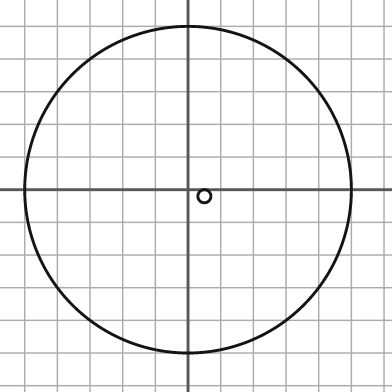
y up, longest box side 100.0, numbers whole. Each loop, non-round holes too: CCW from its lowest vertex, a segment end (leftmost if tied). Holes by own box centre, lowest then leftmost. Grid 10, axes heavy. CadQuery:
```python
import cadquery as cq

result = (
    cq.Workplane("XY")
    .moveTo(0.0, 0.0)
    .circle(50.0)
    .moveTo(5.0, -2.0)
    .circle(2.0)
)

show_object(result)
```